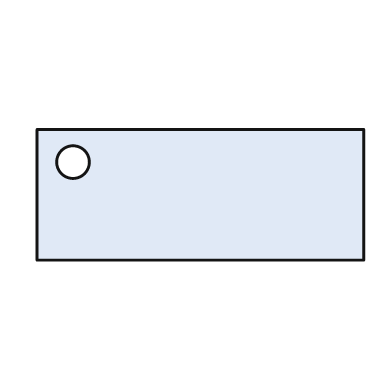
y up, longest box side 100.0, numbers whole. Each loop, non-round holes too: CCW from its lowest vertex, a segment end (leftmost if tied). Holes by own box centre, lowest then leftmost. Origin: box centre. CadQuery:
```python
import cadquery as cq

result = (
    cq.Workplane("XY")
    .moveTo(-50.0, -20.0)
    .lineTo(50.0, -20.0)
    .lineTo(50.0, 20.0)
    .lineTo(-50.0, 20.0)
    .close()
    .moveTo(-39.0, 10.0)
    .circle(5.0)
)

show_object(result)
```